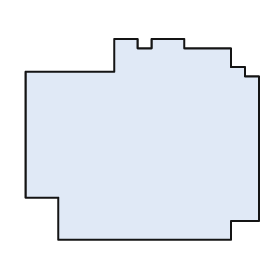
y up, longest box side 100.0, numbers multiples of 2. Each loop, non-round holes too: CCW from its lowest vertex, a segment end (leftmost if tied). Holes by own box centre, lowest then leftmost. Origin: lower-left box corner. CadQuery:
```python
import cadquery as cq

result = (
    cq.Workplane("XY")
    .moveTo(14.0, 0.0)
    .lineTo(88.0, 0.0)
    .lineTo(88.0, 8.0)
    .lineTo(100.0, 8.0)
    .lineTo(100.0, 70.0)
    .lineTo(94.0, 70.0)
    .lineTo(94.0, 74.0)
    .lineTo(88.0, 74.0)
    .lineTo(88.0, 82.0)
    .lineTo(68.0, 82.0)
    .lineTo(68.0, 86.0)
    .lineTo(54.0, 86.0)
    .lineTo(54.0, 82.0)
    .lineTo(48.0, 82.0)
    .lineTo(48.0, 86.0)
    .lineTo(38.0, 86.0)
    .lineTo(38.0, 72.0)
    .lineTo(0.0, 72.0)
    .lineTo(0.0, 18.0)
    .lineTo(14.0, 18.0)
    .close()
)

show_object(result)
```